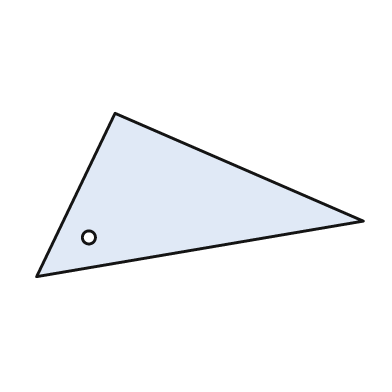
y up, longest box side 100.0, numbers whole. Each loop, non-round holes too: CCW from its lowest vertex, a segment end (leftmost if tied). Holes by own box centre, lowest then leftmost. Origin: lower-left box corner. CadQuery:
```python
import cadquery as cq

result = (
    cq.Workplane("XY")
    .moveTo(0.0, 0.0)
    .lineTo(100.0, 17.0)
    .lineTo(24.0, 50.0)
    .close()
    .moveTo(16.0, 12.0)
    .circle(2.0)
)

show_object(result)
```